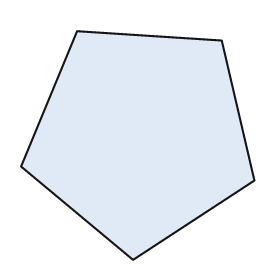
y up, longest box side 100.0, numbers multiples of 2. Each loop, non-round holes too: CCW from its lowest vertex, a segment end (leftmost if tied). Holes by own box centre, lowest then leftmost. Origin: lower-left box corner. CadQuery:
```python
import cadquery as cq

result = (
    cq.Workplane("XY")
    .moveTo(48.0, 0.0)
    .lineTo(100.0, 34.0)
    .lineTo(86.0, 94.0)
    .lineTo(24.0, 98.0)
    .lineTo(0.0, 40.0)
    .close()
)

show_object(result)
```